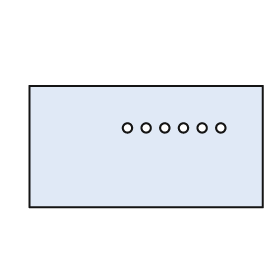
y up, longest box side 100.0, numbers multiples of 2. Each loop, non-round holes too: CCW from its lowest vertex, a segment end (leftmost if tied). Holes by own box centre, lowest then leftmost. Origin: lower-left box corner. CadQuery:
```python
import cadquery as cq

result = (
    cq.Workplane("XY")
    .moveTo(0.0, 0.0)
    .lineTo(100.0, 0.0)
    .lineTo(100.0, 52.0)
    .lineTo(0.0, 52.0)
    .close()
    .moveTo(42.0, 34.0)
    .circle(2.0)
    .moveTo(50.0, 34.0)
    .circle(2.0)
    .moveTo(58.0, 34.0)
    .circle(2.0)
    .moveTo(66.0, 34.0)
    .circle(2.0)
    .moveTo(74.0, 34.0)
    .circle(2.0)
    .moveTo(82.0, 34.0)
    .circle(2.0)
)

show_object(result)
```